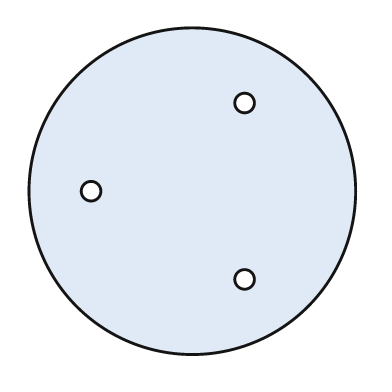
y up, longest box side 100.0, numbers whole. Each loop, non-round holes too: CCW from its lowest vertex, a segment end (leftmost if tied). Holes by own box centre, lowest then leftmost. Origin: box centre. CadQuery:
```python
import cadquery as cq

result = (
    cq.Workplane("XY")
    .moveTo(0.0, 0.0)
    .circle(50.0)
    .moveTo(16.0, -27.0)
    .circle(3.0)
    .moveTo(-31.0, 0.0)
    .circle(3.0)
    .moveTo(16.0, 27.0)
    .circle(3.0)
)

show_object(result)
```